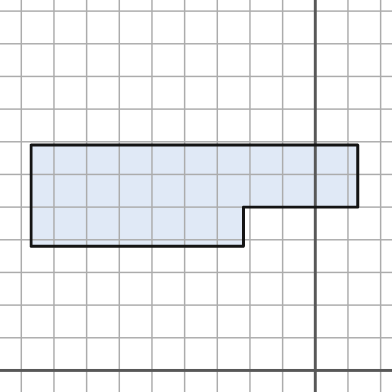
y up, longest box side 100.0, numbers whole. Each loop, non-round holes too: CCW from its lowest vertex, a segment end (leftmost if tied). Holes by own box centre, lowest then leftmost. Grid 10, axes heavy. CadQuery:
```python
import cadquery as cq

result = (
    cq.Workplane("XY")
    .moveTo(-87.0, 38.0)
    .lineTo(-22.0, 38.0)
    .lineTo(-22.0, 50.0)
    .lineTo(13.0, 50.0)
    .lineTo(13.0, 69.0)
    .lineTo(-87.0, 69.0)
    .close()
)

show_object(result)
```